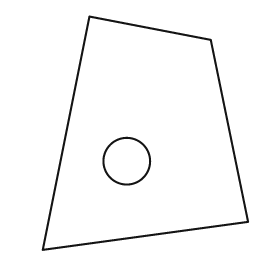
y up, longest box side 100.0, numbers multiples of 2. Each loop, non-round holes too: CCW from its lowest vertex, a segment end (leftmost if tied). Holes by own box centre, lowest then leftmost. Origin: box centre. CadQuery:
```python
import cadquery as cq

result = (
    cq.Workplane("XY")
    .moveTo(-44.0, -50.0)
    .lineTo(44.0, -38.0)
    .lineTo(28.0, 40.0)
    .lineTo(-24.0, 50.0)
    .close()
    .moveTo(-8.0, -12.0)
    .circle(10.0)
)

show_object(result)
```